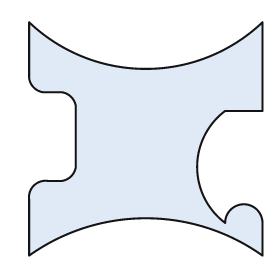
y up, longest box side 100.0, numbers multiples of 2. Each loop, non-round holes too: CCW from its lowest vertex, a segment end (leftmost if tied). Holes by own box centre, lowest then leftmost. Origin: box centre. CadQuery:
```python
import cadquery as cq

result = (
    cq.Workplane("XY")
    .moveTo(-50.0, -50.0)
    .threePointArc((0.0, -34.0), (50.0, -50.0))
    .lineTo(50.0, -36.0)
    .threePointArc((42.0, -28.0), (34.0, -36.0))
    .threePointArc((22.0, -12.0), (34.0, 12.0))
    .lineTo(50.0, 12.0)
    .lineTo(50.0, 50.0)
    .threePointArc((0.0, 30.0), (-50.0, 50.0))
    .lineTo(-50.0, 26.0)
    .threePointArc((-48.0, 22.0), (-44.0, 20.0))
    .lineTo(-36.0, 20.0)
    .threePointArc((-32.0, 18.0), (-30.0, 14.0))
    .lineTo(-30.0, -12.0)
    .threePointArc((-32.0, -16.0), (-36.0, -18.0))
    .lineTo(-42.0, -18.0)
    .threePointArc((-48.0, -20.0), (-50.0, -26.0))
    .close()
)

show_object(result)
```